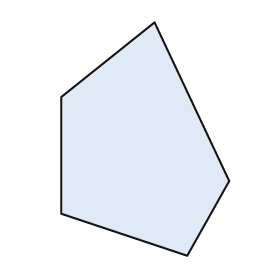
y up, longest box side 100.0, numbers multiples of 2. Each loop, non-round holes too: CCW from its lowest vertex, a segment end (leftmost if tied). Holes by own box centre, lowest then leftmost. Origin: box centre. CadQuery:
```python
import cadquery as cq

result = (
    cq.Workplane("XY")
    .moveTo(18.0, -50.0)
    .lineTo(36.0, -18.0)
    .lineTo(4.0, 50.0)
    .lineTo(-36.0, 18.0)
    .lineTo(-36.0, -32.0)
    .close()
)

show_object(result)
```